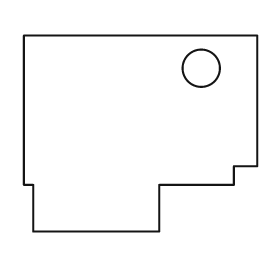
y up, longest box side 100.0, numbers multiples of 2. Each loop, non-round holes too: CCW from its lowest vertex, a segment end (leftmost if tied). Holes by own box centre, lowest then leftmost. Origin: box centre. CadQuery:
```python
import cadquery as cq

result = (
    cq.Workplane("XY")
    .moveTo(-46.0, -42.0)
    .lineTo(8.0, -42.0)
    .lineTo(8.0, -22.0)
    .lineTo(40.0, -22.0)
    .lineTo(40.0, -14.0)
    .lineTo(50.0, -14.0)
    .lineTo(50.0, 42.0)
    .lineTo(-50.0, 42.0)
    .lineTo(-50.0, -22.0)
    .lineTo(-46.0, -22.0)
    .close()
    .moveTo(26.0, 28.0)
    .circle(8.0)
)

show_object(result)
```